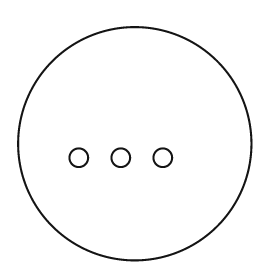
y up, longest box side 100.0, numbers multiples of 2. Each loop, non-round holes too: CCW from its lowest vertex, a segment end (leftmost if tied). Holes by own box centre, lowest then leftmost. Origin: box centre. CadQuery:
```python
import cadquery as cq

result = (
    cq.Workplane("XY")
    .moveTo(0.0, 0.0)
    .circle(50.0)
    .moveTo(-24.0, -6.0)
    .circle(4.0)
    .moveTo(-6.0, -6.0)
    .circle(4.0)
    .moveTo(12.0, -6.0)
    .circle(4.0)
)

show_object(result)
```